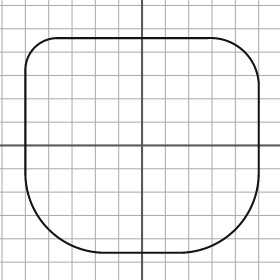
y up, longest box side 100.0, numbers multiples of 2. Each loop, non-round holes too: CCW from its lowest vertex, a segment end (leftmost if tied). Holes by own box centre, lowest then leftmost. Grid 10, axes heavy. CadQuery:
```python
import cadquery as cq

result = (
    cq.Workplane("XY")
    .moveTo(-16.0, -46.0)
    .lineTo(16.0, -46.0)
    .threePointArc((40.0, -36.0), (50.0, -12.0))
    .lineTo(50.0, 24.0)
    .threePointArc((44.0, 40.0), (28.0, 46.0))
    .lineTo(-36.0, 46.0)
    .threePointArc((-46.0, 42.0), (-50.0, 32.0))
    .lineTo(-50.0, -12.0)
    .threePointArc((-40.0, -36.0), (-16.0, -46.0))
    .close()
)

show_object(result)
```